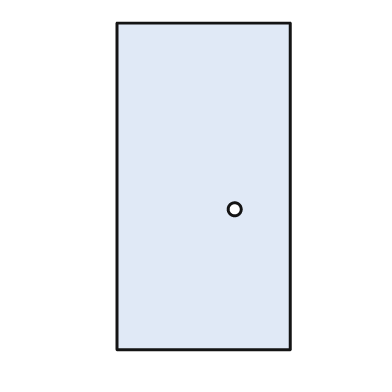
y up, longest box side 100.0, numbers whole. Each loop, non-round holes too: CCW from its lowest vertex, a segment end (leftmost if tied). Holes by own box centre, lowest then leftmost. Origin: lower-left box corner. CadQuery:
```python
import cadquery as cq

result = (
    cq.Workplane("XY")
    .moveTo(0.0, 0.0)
    .lineTo(53.0, 0.0)
    .lineTo(53.0, 100.0)
    .lineTo(0.0, 100.0)
    .close()
    .moveTo(36.0, 43.0)
    .circle(2.0)
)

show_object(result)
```